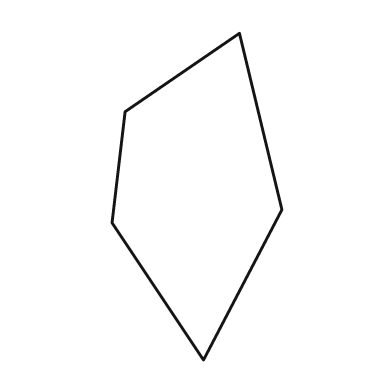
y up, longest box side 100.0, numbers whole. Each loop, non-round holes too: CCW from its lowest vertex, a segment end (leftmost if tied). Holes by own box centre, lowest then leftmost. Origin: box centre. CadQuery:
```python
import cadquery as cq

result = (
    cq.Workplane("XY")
    .moveTo(2.0, -50.0)
    .lineTo(26.0, -4.0)
    .lineTo(13.0, 50.0)
    .lineTo(-22.0, 26.0)
    .lineTo(-26.0, -8.0)
    .close()
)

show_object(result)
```